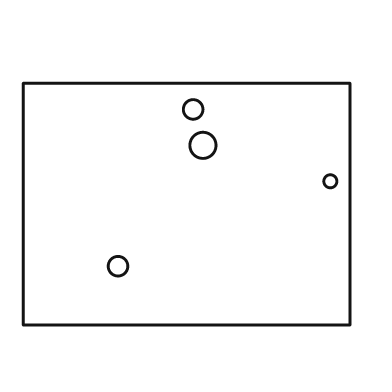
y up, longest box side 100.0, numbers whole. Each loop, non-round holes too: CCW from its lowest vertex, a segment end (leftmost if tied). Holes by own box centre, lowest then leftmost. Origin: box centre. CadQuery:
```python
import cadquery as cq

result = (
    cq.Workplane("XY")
    .moveTo(-50.0, -37.0)
    .lineTo(50.0, -37.0)
    .lineTo(50.0, 37.0)
    .lineTo(-50.0, 37.0)
    .close()
    .moveTo(-21.0, -19.0)
    .circle(3.0)
    .moveTo(44.0, 7.0)
    .circle(2.0)
    .moveTo(5.0, 18.0)
    .circle(4.0)
    .moveTo(2.0, 29.0)
    .circle(3.0)
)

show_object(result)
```